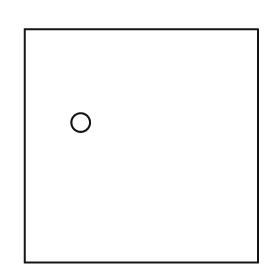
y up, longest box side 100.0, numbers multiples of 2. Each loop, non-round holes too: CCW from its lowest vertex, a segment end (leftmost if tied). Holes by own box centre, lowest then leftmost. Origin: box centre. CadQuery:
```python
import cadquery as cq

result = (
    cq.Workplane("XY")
    .moveTo(-50.0, -50.0)
    .lineTo(50.0, -50.0)
    .lineTo(50.0, 50.0)
    .lineTo(-50.0, 50.0)
    .close()
    .moveTo(-26.0, 10.0)
    .circle(4.0)
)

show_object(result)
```